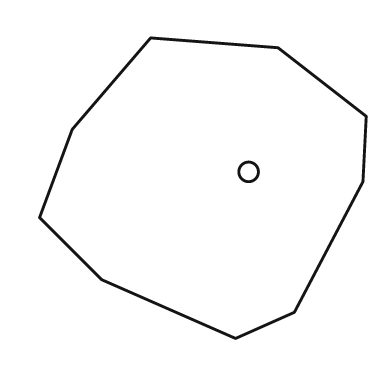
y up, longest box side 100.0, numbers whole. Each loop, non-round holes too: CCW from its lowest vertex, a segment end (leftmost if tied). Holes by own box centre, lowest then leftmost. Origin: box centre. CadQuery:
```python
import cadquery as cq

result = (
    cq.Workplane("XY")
    .moveTo(10.0, -46.0)
    .lineTo(28.0, -38.0)
    .lineTo(49.0, 2.0)
    .lineTo(50.0, 22.0)
    .lineTo(23.0, 43.0)
    .lineTo(-16.0, 46.0)
    .lineTo(-40.0, 18.0)
    .lineTo(-50.0, -9.0)
    .lineTo(-31.0, -28.0)
    .close()
    .moveTo(14.0, 5.0)
    .circle(3.0)
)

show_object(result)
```